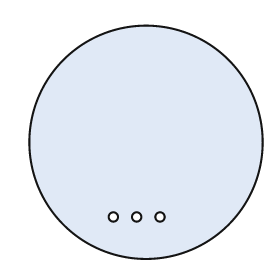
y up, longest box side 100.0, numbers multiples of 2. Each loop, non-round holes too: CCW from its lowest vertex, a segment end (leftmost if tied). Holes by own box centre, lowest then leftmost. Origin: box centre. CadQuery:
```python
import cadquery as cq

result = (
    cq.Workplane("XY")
    .moveTo(0.0, 0.0)
    .circle(50.0)
    .moveTo(-14.0, -32.0)
    .circle(2.0)
    .moveTo(-4.0, -32.0)
    .circle(2.0)
    .moveTo(6.0, -32.0)
    .circle(2.0)
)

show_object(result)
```